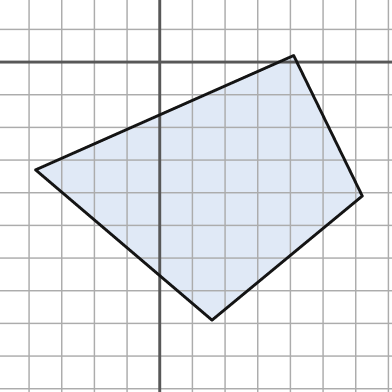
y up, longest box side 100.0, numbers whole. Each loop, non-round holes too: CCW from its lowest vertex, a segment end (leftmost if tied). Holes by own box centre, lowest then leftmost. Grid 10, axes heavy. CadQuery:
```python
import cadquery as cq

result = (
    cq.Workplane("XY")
    .moveTo(16.0, -79.0)
    .lineTo(62.0, -41.0)
    .lineTo(41.0, 2.0)
    .lineTo(-38.0, -33.0)
    .close()
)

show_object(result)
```